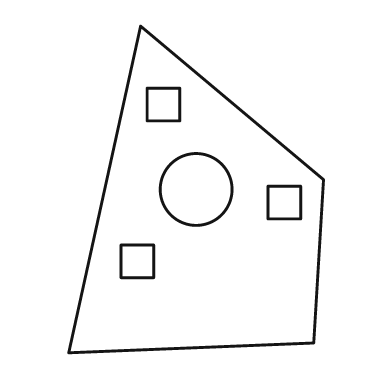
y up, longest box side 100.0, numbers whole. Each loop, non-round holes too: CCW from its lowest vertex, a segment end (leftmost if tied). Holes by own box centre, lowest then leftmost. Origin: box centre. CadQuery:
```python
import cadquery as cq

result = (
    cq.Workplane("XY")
    .moveTo(-39.0, -50.0)
    .lineTo(36.0, -47.0)
    .lineTo(39.0, 3.0)
    .lineTo(-17.0, 50.0)
    .close()
    .moveTo(-23.0, -27.0)
    .lineTo(-13.0, -27.0)
    .lineTo(-13.0, -17.0)
    .lineTo(-23.0, -17.0)
    .close()
    .moveTo(22.0, -9.0)
    .lineTo(32.0, -9.0)
    .lineTo(32.0, 1.0)
    .lineTo(22.0, 1.0)
    .close()
    .moveTo(0.0, 0.0)
    .circle(11.0)
    .moveTo(-15.0, 21.0)
    .lineTo(-5.0, 21.0)
    .lineTo(-5.0, 31.0)
    .lineTo(-15.0, 31.0)
    .close()
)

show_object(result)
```